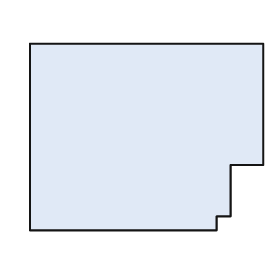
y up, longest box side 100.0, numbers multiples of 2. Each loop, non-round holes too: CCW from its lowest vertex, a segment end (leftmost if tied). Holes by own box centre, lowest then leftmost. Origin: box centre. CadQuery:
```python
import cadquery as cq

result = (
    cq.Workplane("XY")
    .moveTo(-50.0, -40.0)
    .lineTo(30.0, -40.0)
    .lineTo(30.0, -34.0)
    .lineTo(36.0, -34.0)
    .lineTo(36.0, -12.0)
    .lineTo(50.0, -12.0)
    .lineTo(50.0, 40.0)
    .lineTo(-50.0, 40.0)
    .close()
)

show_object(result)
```